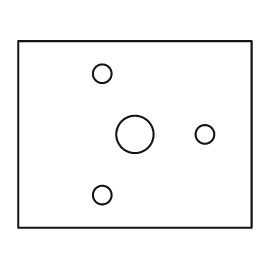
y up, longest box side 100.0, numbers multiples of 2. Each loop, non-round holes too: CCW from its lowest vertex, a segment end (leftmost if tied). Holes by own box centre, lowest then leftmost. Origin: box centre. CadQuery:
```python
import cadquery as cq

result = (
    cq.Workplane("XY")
    .moveTo(-50.0, -40.0)
    .lineTo(50.0, -40.0)
    .lineTo(50.0, 40.0)
    .lineTo(-50.0, 40.0)
    .close()
    .moveTo(-14.0, -26.0)
    .circle(4.0)
    .moveTo(0.0, 0.0)
    .circle(8.0)
    .moveTo(30.0, 0.0)
    .circle(4.0)
    .moveTo(-14.0, 26.0)
    .circle(4.0)
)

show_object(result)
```